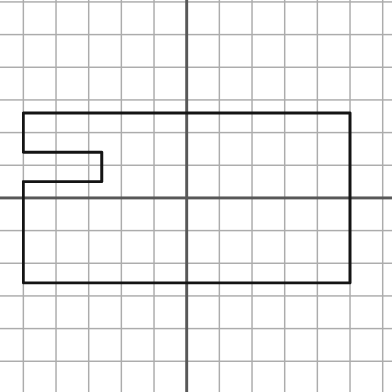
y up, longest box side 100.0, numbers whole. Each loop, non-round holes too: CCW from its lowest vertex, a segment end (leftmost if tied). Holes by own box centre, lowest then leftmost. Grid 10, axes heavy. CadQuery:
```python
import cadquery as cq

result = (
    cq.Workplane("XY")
    .moveTo(-50.0, -26.0)
    .lineTo(50.0, -26.0)
    .lineTo(50.0, 26.0)
    .lineTo(-50.0, 26.0)
    .lineTo(-50.0, 14.0)
    .lineTo(-26.0, 14.0)
    .lineTo(-26.0, 5.0)
    .lineTo(-50.0, 5.0)
    .close()
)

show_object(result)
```